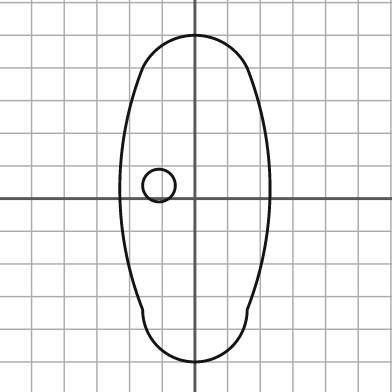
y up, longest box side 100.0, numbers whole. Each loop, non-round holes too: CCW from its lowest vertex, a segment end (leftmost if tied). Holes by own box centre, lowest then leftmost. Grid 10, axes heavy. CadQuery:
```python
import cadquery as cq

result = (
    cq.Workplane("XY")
    .moveTo(-16.0, -34.0)
    .threePointArc((0.0, -50.0), (16.0, -34.0))
    .threePointArc((23.0, 3.0), (16.0, 40.0))
    .threePointArc((0.0, 50.0), (-16.0, 40.0))
    .threePointArc((-23.0, 3.0), (-16.0, -34.0))
    .close()
    .moveTo(-11.0, 4.0)
    .circle(5.0)
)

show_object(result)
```